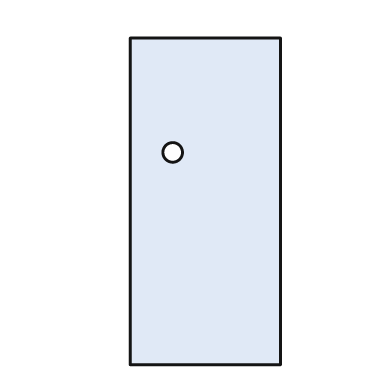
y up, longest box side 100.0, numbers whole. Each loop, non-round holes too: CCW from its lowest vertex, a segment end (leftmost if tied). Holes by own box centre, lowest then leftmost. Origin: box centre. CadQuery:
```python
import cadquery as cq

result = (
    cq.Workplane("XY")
    .moveTo(-23.0, -50.0)
    .lineTo(23.0, -50.0)
    .lineTo(23.0, 50.0)
    .lineTo(-23.0, 50.0)
    .close()
    .moveTo(-10.0, 15.0)
    .circle(3.0)
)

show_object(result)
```